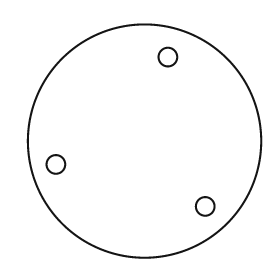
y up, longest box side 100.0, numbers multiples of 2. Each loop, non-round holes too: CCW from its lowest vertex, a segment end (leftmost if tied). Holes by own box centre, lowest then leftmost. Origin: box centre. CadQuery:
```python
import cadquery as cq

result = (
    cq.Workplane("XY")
    .moveTo(0.0, 0.0)
    .circle(50.0)
    .moveTo(26.0, -28.0)
    .circle(4.0)
    .moveTo(-38.0, -10.0)
    .circle(4.0)
    .moveTo(10.0, 36.0)
    .circle(4.0)
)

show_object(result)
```